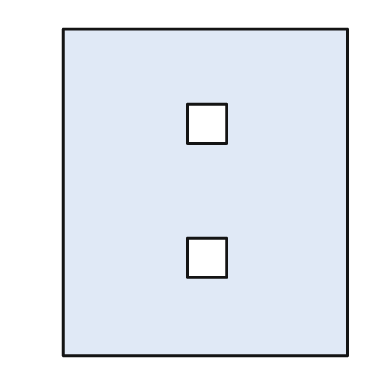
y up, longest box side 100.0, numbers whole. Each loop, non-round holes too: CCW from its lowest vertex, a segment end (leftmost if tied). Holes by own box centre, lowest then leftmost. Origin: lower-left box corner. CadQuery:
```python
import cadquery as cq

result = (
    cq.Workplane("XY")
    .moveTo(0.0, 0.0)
    .lineTo(87.0, 0.0)
    .lineTo(87.0, 100.0)
    .lineTo(0.0, 100.0)
    .close()
    .moveTo(38.0, 24.0)
    .lineTo(50.0, 24.0)
    .lineTo(50.0, 36.0)
    .lineTo(38.0, 36.0)
    .close()
    .moveTo(38.0, 65.0)
    .lineTo(50.0, 65.0)
    .lineTo(50.0, 77.0)
    .lineTo(38.0, 77.0)
    .close()
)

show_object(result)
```